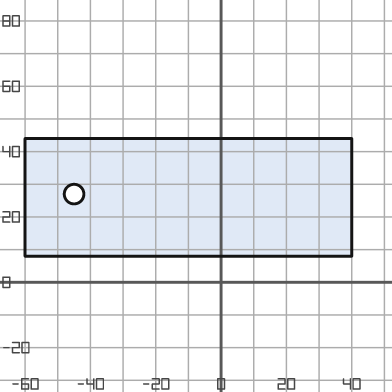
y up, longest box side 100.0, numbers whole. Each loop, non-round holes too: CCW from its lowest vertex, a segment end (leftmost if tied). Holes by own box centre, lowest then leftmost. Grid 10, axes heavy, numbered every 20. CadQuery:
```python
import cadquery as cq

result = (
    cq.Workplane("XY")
    .moveTo(-60.0, 8.0)
    .lineTo(40.0, 8.0)
    .lineTo(40.0, 44.0)
    .lineTo(-60.0, 44.0)
    .close()
    .moveTo(-45.0, 27.0)
    .circle(3.0)
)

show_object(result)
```